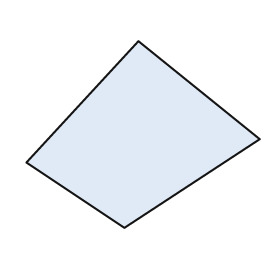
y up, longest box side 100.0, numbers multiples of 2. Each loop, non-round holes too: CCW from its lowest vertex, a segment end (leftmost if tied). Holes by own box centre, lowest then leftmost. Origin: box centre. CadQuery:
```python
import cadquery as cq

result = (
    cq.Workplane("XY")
    .moveTo(-8.0, -40.0)
    .lineTo(50.0, -2.0)
    .lineTo(-2.0, 40.0)
    .lineTo(-50.0, -12.0)
    .close()
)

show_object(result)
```